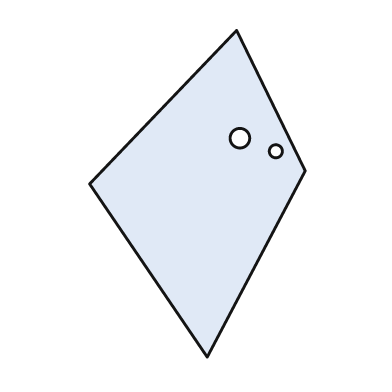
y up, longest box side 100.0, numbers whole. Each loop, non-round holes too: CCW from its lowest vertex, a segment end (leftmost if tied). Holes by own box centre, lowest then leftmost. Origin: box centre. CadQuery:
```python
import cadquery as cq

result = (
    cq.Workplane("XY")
    .moveTo(3.0, -50.0)
    .lineTo(33.0, 7.0)
    .lineTo(12.0, 50.0)
    .lineTo(-33.0, 3.0)
    .close()
    .moveTo(24.0, 13.0)
    .circle(2.0)
    .moveTo(13.0, 17.0)
    .circle(3.0)
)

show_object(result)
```